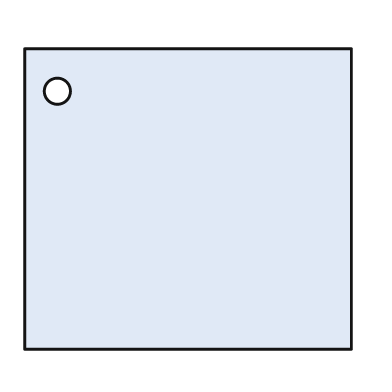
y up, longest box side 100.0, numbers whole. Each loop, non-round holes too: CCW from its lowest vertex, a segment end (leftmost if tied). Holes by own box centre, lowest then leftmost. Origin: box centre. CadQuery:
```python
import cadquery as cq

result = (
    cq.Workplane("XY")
    .moveTo(-50.0, -46.0)
    .lineTo(50.0, -46.0)
    .lineTo(50.0, 46.0)
    .lineTo(-50.0, 46.0)
    .close()
    .moveTo(-40.0, 33.0)
    .circle(4.0)
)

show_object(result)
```